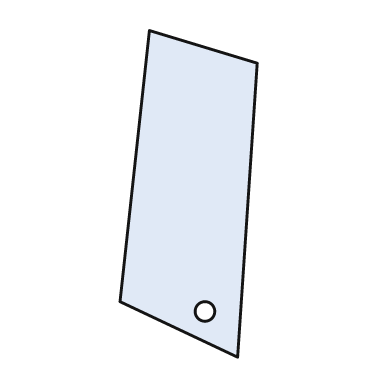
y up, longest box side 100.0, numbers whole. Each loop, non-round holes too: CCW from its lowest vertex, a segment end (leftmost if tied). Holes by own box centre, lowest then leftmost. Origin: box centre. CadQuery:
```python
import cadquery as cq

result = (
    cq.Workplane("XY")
    .moveTo(15.0, -50.0)
    .lineTo(21.0, 40.0)
    .lineTo(-12.0, 50.0)
    .lineTo(-21.0, -33.0)
    .close()
    .moveTo(5.0, -36.0)
    .circle(3.0)
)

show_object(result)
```